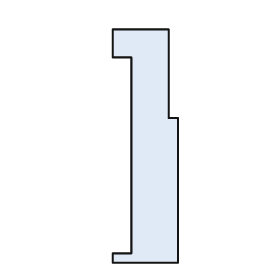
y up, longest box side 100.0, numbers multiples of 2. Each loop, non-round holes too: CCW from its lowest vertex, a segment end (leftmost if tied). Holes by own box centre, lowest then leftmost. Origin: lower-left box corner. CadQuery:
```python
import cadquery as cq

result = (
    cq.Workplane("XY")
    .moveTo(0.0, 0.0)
    .lineTo(28.0, 0.0)
    .lineTo(28.0, 62.0)
    .lineTo(24.0, 62.0)
    .lineTo(24.0, 100.0)
    .lineTo(0.0, 100.0)
    .lineTo(0.0, 88.0)
    .lineTo(8.0, 88.0)
    .lineTo(8.0, 4.0)
    .lineTo(0.0, 4.0)
    .close()
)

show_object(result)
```